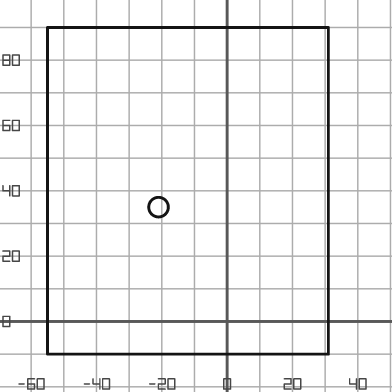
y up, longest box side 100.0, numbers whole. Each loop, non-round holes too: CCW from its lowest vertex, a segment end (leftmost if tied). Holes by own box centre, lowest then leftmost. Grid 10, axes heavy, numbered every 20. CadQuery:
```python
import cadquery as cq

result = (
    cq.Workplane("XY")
    .moveTo(-55.0, -10.0)
    .lineTo(31.0, -10.0)
    .lineTo(31.0, 90.0)
    .lineTo(-55.0, 90.0)
    .close()
    .moveTo(-21.0, 35.0)
    .circle(3.0)
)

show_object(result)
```